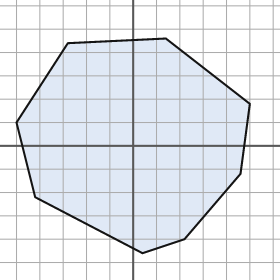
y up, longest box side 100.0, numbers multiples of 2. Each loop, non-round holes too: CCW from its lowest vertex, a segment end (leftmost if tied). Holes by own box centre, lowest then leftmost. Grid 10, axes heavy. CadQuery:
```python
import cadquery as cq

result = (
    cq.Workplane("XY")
    .moveTo(4.0, -46.0)
    .lineTo(22.0, -40.0)
    .lineTo(46.0, -12.0)
    .lineTo(50.0, 18.0)
    .lineTo(14.0, 46.0)
    .lineTo(-28.0, 44.0)
    .lineTo(-50.0, 10.0)
    .lineTo(-42.0, -22.0)
    .close()
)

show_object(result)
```